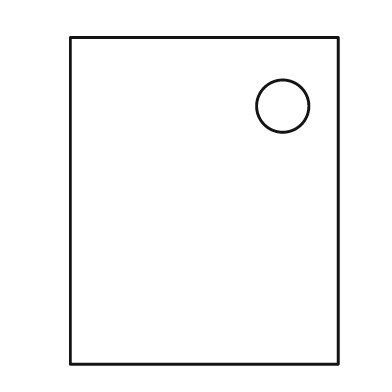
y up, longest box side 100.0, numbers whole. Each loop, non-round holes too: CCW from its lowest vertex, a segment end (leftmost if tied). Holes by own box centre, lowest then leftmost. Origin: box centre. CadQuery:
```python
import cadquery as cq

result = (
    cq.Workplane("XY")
    .moveTo(-41.0, -50.0)
    .lineTo(41.0, -50.0)
    .lineTo(41.0, 50.0)
    .lineTo(-41.0, 50.0)
    .close()
    .moveTo(24.0, 29.0)
    .circle(8.0)
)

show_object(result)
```